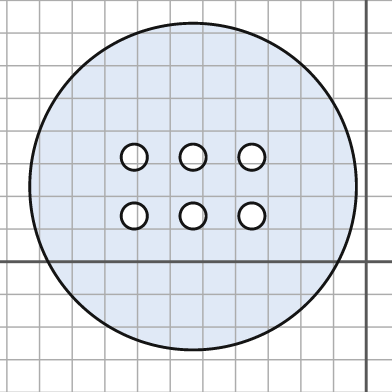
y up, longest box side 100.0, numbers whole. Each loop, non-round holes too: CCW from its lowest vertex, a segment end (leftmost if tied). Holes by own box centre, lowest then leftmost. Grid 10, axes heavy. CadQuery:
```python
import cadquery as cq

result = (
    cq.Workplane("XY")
    .moveTo(-53.0, 23.0)
    .circle(50.0)
    .moveTo(-71.0, 14.0)
    .circle(4.0)
    .moveTo(-53.0, 14.0)
    .circle(4.0)
    .moveTo(-35.0, 14.0)
    .circle(4.0)
    .moveTo(-71.0, 32.0)
    .circle(4.0)
    .moveTo(-53.0, 32.0)
    .circle(4.0)
    .moveTo(-35.0, 32.0)
    .circle(4.0)
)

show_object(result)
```